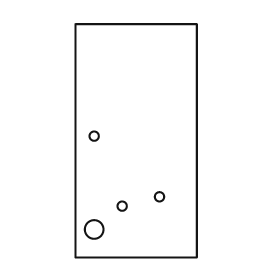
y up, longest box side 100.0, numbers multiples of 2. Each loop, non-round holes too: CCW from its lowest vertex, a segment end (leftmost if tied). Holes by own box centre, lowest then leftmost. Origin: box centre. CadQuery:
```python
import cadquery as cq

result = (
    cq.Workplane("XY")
    .moveTo(-26.0, -50.0)
    .lineTo(26.0, -50.0)
    .lineTo(26.0, 50.0)
    .lineTo(-26.0, 50.0)
    .close()
    .moveTo(-18.0, -38.0)
    .circle(4.0)
    .moveTo(-6.0, -28.0)
    .circle(2.0)
    .moveTo(10.0, -24.0)
    .circle(2.0)
    .moveTo(-18.0, 2.0)
    .circle(2.0)
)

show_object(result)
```